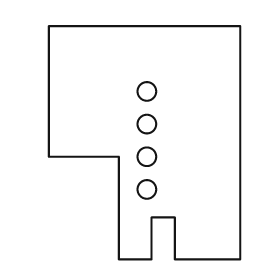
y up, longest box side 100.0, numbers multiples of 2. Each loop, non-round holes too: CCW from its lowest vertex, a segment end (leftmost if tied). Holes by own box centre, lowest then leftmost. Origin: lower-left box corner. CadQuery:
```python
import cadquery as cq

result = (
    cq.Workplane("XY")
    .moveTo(30.0, 0.0)
    .lineTo(44.0, 0.0)
    .lineTo(44.0, 18.0)
    .lineTo(54.0, 18.0)
    .lineTo(54.0, 0.0)
    .lineTo(82.0, 0.0)
    .lineTo(82.0, 100.0)
    .lineTo(0.0, 100.0)
    .lineTo(0.0, 44.0)
    .lineTo(30.0, 44.0)
    .close()
    .moveTo(42.0, 30.0)
    .circle(4.0)
    .moveTo(42.0, 44.0)
    .circle(4.0)
    .moveTo(42.0, 58.0)
    .circle(4.0)
    .moveTo(42.0, 72.0)
    .circle(4.0)
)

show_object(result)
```